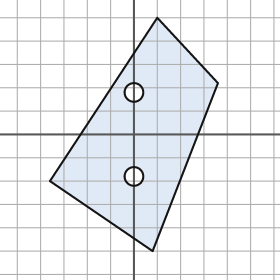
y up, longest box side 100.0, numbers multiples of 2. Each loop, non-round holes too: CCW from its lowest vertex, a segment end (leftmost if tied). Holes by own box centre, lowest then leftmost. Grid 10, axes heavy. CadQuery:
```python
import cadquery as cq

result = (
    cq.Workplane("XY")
    .moveTo(8.0, -50.0)
    .lineTo(36.0, 22.0)
    .lineTo(10.0, 50.0)
    .lineTo(-36.0, -20.0)
    .close()
    .moveTo(0.0, -18.0)
    .circle(4.0)
    .moveTo(0.0, 18.0)
    .circle(4.0)
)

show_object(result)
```